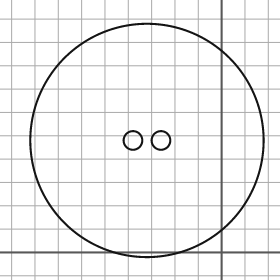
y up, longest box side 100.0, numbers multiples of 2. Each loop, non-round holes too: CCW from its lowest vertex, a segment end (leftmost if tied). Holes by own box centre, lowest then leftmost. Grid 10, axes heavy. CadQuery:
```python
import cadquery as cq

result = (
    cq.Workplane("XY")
    .moveTo(-32.0, 48.0)
    .circle(50.0)
    .moveTo(-38.0, 48.0)
    .circle(4.0)
    .moveTo(-26.0, 48.0)
    .circle(4.0)
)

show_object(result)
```